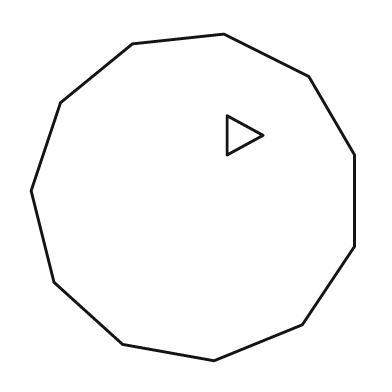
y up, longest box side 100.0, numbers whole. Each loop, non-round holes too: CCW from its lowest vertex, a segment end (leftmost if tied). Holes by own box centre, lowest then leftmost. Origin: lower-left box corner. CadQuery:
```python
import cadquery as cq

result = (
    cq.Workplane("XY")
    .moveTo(56.0, 0.0)
    .lineTo(83.0, 11.0)
    .lineTo(99.0, 35.0)
    .lineTo(99.0, 63.0)
    .lineTo(85.0, 87.0)
    .lineTo(59.0, 100.0)
    .lineTo(31.0, 97.0)
    .lineTo(9.0, 79.0)
    .lineTo(0.0, 52.0)
    .lineTo(7.0, 24.0)
    .lineTo(28.0, 5.0)
    .close()
    .moveTo(60.0, 63.0)
    .lineTo(71.0, 69.0)
    .lineTo(60.0, 75.0)
    .close()
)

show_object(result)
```